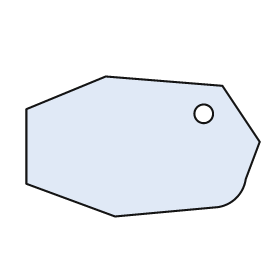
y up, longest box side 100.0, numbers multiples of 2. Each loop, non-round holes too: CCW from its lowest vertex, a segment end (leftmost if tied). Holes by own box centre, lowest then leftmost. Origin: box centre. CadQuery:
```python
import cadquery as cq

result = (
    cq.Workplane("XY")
    .moveTo(-12.0, -30.0)
    .lineTo(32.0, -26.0)
    .threePointArc((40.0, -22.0), (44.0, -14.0))
    .lineTo(50.0, 2.0)
    .lineTo(34.0, 26.0)
    .lineTo(-16.0, 30.0)
    .lineTo(-50.0, 16.0)
    .lineTo(-50.0, -16.0)
    .close()
    .moveTo(26.0, 14.0)
    .circle(4.0)
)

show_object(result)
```